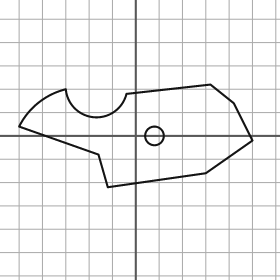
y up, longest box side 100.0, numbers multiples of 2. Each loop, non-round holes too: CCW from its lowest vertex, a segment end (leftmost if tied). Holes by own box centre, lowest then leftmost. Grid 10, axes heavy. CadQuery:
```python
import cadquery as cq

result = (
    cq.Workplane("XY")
    .moveTo(-12.0, -22.0)
    .lineTo(30.0, -16.0)
    .lineTo(50.0, -2.0)
    .lineTo(42.0, 14.0)
    .lineTo(32.0, 22.0)
    .lineTo(-4.0, 18.0)
    .threePointArc((-18.0, 8.0), (-30.0, 20.0))
    .threePointArc((-42.0, 14.0), (-50.0, 4.0))
    .lineTo(-16.0, -8.0)
    .close()
    .moveTo(8.0, 0.0)
    .circle(4.0)
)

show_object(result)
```